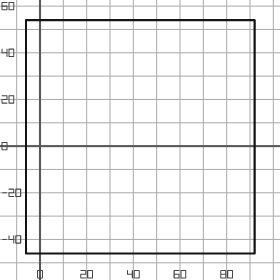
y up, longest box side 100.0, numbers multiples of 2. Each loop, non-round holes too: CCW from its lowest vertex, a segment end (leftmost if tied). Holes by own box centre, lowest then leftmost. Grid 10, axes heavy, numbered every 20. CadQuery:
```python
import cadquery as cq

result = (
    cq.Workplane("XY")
    .moveTo(-6.0, -46.0)
    .lineTo(92.0, -46.0)
    .lineTo(92.0, 54.0)
    .lineTo(-6.0, 54.0)
    .close()
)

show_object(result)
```